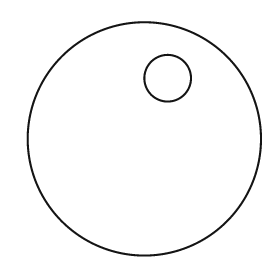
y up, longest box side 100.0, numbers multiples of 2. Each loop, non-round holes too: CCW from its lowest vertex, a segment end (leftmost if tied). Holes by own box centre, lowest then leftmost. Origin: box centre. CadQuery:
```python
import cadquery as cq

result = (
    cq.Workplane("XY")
    .moveTo(0.0, 0.0)
    .circle(50.0)
    .moveTo(10.0, 26.0)
    .circle(10.0)
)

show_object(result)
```